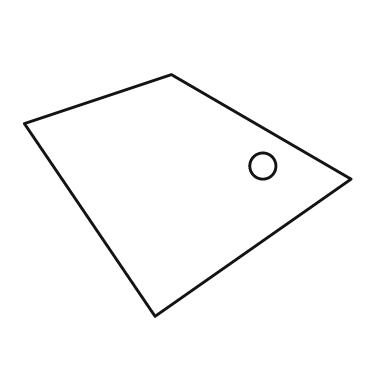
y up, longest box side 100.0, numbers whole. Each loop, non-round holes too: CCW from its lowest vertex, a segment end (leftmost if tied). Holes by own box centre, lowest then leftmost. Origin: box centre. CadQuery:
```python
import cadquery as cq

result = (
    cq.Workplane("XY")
    .moveTo(-10.0, -37.0)
    .lineTo(50.0, 5.0)
    .lineTo(-5.0, 37.0)
    .lineTo(-50.0, 22.0)
    .close()
    .moveTo(23.0, 9.0)
    .circle(4.0)
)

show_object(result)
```